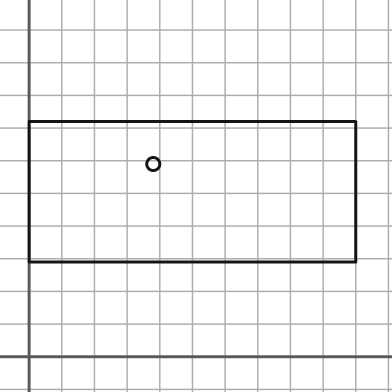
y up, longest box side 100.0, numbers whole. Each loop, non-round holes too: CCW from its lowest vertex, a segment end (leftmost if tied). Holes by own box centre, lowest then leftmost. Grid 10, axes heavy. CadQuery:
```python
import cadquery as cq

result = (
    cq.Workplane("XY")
    .moveTo(0.0, 29.0)
    .lineTo(100.0, 29.0)
    .lineTo(100.0, 72.0)
    .lineTo(0.0, 72.0)
    .close()
    .moveTo(38.0, 59.0)
    .circle(2.0)
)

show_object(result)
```